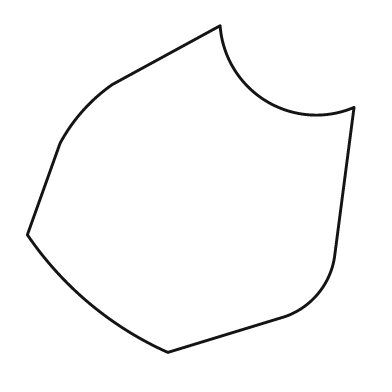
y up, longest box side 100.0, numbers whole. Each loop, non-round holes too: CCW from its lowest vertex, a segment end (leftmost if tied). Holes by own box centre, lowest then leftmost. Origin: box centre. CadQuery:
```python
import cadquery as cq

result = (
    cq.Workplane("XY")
    .moveTo(-7.0, -50.0)
    .lineTo(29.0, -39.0)
    .threePointArc((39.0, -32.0), (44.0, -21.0))
    .lineTo(50.0, 25.0)
    .threePointArc((23.0, 27.0), (9.0, 50.0))
    .lineTo(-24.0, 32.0)
    .threePointArc((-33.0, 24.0), (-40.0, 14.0))
    .lineTo(-50.0, -14.0)
    .threePointArc((-31.0, -35.0), (-7.0, -50.0))
    .close()
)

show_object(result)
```